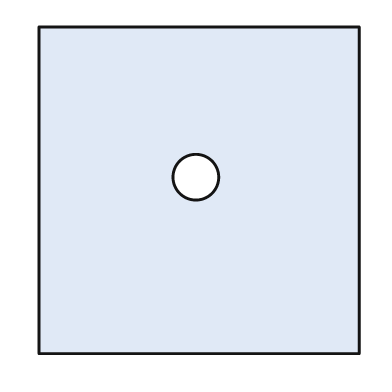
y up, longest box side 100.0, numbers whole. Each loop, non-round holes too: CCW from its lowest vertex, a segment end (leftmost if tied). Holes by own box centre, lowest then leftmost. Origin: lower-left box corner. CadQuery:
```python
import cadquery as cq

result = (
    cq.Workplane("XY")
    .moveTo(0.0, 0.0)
    .lineTo(98.0, 0.0)
    .lineTo(98.0, 100.0)
    .lineTo(0.0, 100.0)
    .close()
    .moveTo(48.0, 54.0)
    .circle(7.0)
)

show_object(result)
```